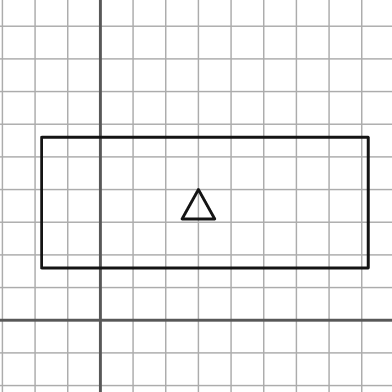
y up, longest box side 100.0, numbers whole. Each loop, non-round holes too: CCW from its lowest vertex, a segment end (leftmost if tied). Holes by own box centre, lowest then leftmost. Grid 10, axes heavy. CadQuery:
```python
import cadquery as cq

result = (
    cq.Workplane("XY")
    .moveTo(-18.0, 16.0)
    .lineTo(82.0, 16.0)
    .lineTo(82.0, 56.0)
    .lineTo(-18.0, 56.0)
    .close()
    .moveTo(25.0, 31.0)
    .lineTo(35.0, 31.0)
    .lineTo(30.0, 40.0)
    .close()
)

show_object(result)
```